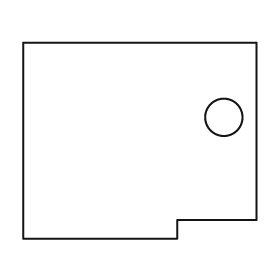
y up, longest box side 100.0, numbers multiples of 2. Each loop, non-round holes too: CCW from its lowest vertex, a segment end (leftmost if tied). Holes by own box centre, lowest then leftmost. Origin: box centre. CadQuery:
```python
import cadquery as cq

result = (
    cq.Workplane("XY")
    .moveTo(-50.0, -42.0)
    .lineTo(16.0, -42.0)
    .lineTo(16.0, -34.0)
    .lineTo(50.0, -34.0)
    .lineTo(50.0, 42.0)
    .lineTo(-50.0, 42.0)
    .close()
    .moveTo(36.0, 10.0)
    .circle(8.0)
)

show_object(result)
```